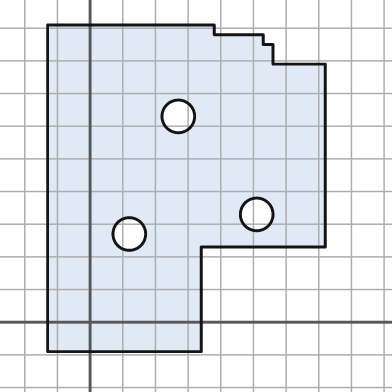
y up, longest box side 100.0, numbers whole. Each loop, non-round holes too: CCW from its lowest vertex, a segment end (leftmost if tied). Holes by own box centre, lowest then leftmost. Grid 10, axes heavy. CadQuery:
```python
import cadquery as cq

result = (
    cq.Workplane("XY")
    .moveTo(-13.0, -9.0)
    .lineTo(34.0, -9.0)
    .lineTo(34.0, 23.0)
    .lineTo(72.0, 23.0)
    .lineTo(72.0, 79.0)
    .lineTo(56.0, 79.0)
    .lineTo(56.0, 85.0)
    .lineTo(53.0, 85.0)
    .lineTo(53.0, 88.0)
    .lineTo(38.0, 88.0)
    .lineTo(38.0, 91.0)
    .lineTo(-13.0, 91.0)
    .close()
    .moveTo(12.0, 27.0)
    .circle(5.0)
    .moveTo(51.0, 33.0)
    .circle(5.0)
    .moveTo(27.0, 63.0)
    .circle(5.0)
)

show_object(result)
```